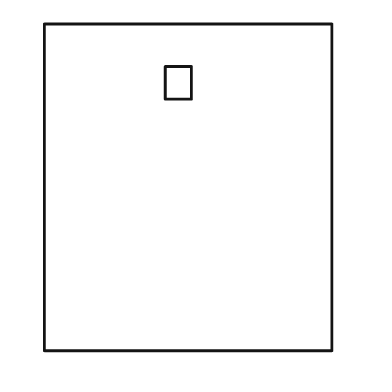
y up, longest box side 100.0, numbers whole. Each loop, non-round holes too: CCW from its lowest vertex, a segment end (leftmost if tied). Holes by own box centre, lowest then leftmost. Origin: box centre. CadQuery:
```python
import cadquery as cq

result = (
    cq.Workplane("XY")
    .moveTo(-44.0, -50.0)
    .lineTo(44.0, -50.0)
    .lineTo(44.0, 50.0)
    .lineTo(-44.0, 50.0)
    .close()
    .moveTo(-7.0, 27.0)
    .lineTo(1.0, 27.0)
    .lineTo(1.0, 37.0)
    .lineTo(-7.0, 37.0)
    .close()
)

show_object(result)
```